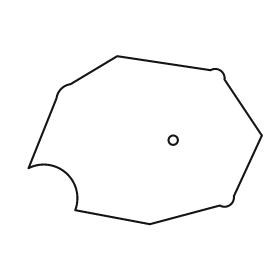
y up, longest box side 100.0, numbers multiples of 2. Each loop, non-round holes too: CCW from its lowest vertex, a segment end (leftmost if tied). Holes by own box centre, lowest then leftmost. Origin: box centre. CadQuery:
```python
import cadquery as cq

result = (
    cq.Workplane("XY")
    .moveTo(2.0, -36.0)
    .lineTo(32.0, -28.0)
    .threePointArc((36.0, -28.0), (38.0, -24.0))
    .lineTo(50.0, 2.0)
    .lineTo(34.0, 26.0)
    .threePointArc((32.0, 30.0), (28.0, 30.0))
    .lineTo(-12.0, 36.0)
    .lineTo(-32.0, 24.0)
    .threePointArc((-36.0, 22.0), (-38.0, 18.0))
    .lineTo(-50.0, -12.0)
    .threePointArc((-34.0, -14.0), (-30.0, -30.0))
    .close()
    .moveTo(12.0, 0.0)
    .circle(2.0)
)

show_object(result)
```